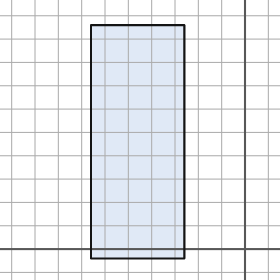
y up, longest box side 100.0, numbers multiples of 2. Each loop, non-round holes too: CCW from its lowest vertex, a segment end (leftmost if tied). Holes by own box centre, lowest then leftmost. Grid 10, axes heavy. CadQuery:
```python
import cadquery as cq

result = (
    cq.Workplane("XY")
    .moveTo(-66.0, -4.0)
    .lineTo(-26.0, -4.0)
    .lineTo(-26.0, 96.0)
    .lineTo(-66.0, 96.0)
    .close()
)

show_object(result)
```